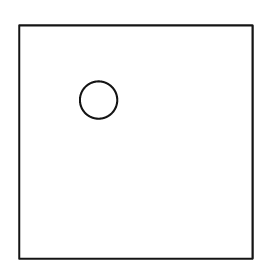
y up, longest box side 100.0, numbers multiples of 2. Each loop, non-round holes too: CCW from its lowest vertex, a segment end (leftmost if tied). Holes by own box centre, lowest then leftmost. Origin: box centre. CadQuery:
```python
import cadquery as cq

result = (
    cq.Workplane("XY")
    .moveTo(-50.0, -50.0)
    .lineTo(50.0, -50.0)
    .lineTo(50.0, 50.0)
    .lineTo(-50.0, 50.0)
    .close()
    .moveTo(-16.0, 18.0)
    .circle(8.0)
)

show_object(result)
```